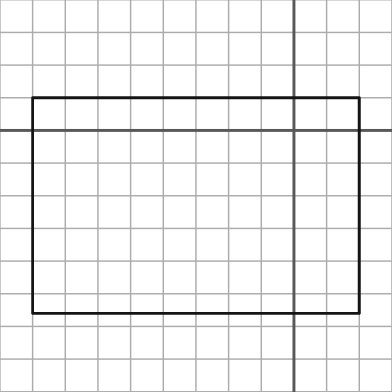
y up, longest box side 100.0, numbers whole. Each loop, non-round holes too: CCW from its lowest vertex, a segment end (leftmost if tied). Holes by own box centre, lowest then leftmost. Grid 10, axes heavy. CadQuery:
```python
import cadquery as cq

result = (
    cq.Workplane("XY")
    .moveTo(-80.0, -56.0)
    .lineTo(20.0, -56.0)
    .lineTo(20.0, 10.0)
    .lineTo(-80.0, 10.0)
    .close()
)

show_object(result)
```